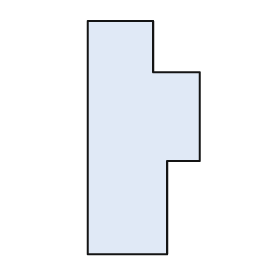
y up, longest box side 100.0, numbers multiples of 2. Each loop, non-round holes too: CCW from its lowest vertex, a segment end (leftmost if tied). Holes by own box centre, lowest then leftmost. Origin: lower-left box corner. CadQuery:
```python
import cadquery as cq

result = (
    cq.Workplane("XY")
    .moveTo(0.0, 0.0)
    .lineTo(34.0, 0.0)
    .lineTo(34.0, 40.0)
    .lineTo(48.0, 40.0)
    .lineTo(48.0, 78.0)
    .lineTo(28.0, 78.0)
    .lineTo(28.0, 100.0)
    .lineTo(0.0, 100.0)
    .close()
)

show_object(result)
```